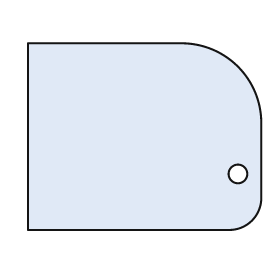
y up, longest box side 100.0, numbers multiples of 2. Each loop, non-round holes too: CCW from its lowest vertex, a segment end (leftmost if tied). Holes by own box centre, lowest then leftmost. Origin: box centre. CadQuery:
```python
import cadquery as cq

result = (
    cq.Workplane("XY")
    .moveTo(-50.0, -40.0)
    .lineTo(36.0, -40.0)
    .threePointArc((46.0, -36.0), (50.0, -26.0))
    .lineTo(50.0, 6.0)
    .threePointArc((40.0, 30.0), (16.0, 40.0))
    .lineTo(-50.0, 40.0)
    .close()
    .moveTo(40.0, -16.0)
    .circle(4.0)
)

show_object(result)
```